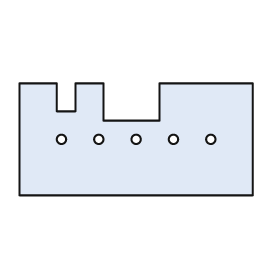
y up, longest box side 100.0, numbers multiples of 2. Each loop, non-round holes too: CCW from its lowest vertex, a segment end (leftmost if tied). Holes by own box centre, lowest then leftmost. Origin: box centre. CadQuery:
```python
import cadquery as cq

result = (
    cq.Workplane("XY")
    .moveTo(-50.0, -24.0)
    .lineTo(50.0, -24.0)
    .lineTo(50.0, 24.0)
    .lineTo(10.0, 24.0)
    .lineTo(10.0, 8.0)
    .lineTo(-14.0, 8.0)
    .lineTo(-14.0, 24.0)
    .lineTo(-26.0, 24.0)
    .lineTo(-26.0, 12.0)
    .lineTo(-34.0, 12.0)
    .lineTo(-34.0, 24.0)
    .lineTo(-50.0, 24.0)
    .close()
    .moveTo(-32.0, 0.0)
    .circle(2.0)
    .moveTo(-16.0, 0.0)
    .circle(2.0)
    .moveTo(0.0, 0.0)
    .circle(2.0)
    .moveTo(16.0, 0.0)
    .circle(2.0)
    .moveTo(32.0, 0.0)
    .circle(2.0)
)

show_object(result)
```